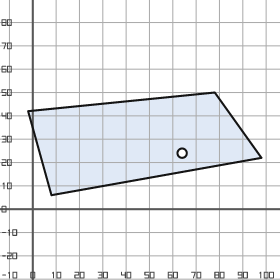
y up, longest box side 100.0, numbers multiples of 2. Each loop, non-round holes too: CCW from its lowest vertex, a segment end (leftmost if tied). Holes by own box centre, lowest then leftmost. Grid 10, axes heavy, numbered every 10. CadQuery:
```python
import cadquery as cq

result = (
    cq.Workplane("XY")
    .moveTo(8.0, 6.0)
    .lineTo(98.0, 22.0)
    .lineTo(78.0, 50.0)
    .lineTo(-2.0, 42.0)
    .close()
    .moveTo(64.0, 24.0)
    .circle(2.0)
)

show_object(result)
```